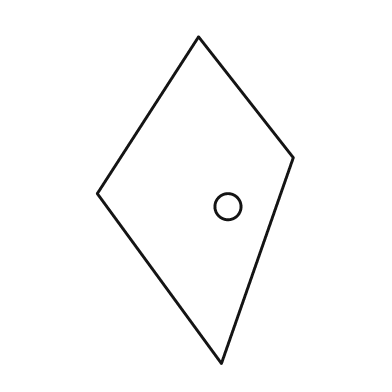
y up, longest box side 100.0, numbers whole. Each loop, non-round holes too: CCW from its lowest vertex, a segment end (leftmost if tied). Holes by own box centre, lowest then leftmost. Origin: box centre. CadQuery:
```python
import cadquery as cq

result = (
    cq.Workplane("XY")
    .moveTo(8.0, -50.0)
    .lineTo(30.0, 13.0)
    .lineTo(1.0, 50.0)
    .lineTo(-30.0, 2.0)
    .close()
    .moveTo(10.0, -2.0)
    .circle(4.0)
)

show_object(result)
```